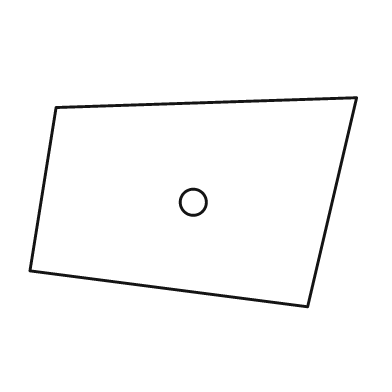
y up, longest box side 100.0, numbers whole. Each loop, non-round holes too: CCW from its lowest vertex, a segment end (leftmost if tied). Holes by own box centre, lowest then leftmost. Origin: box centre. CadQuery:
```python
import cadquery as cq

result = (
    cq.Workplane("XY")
    .moveTo(35.0, -32.0)
    .lineTo(50.0, 32.0)
    .lineTo(-42.0, 29.0)
    .lineTo(-50.0, -21.0)
    .close()
    .moveTo(0.0, 0.0)
    .circle(4.0)
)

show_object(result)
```